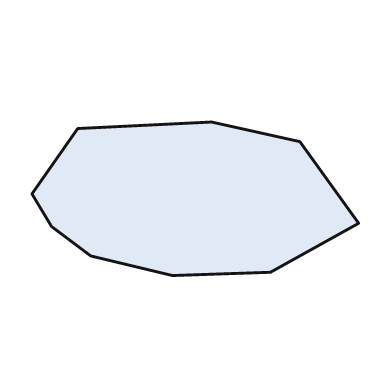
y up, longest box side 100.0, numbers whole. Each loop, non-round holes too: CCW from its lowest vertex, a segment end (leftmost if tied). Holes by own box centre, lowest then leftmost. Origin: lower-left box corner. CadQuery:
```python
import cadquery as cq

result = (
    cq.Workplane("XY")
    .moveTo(43.0, 0.0)
    .lineTo(73.0, 1.0)
    .lineTo(100.0, 16.0)
    .lineTo(82.0, 41.0)
    .lineTo(55.0, 47.0)
    .lineTo(14.0, 45.0)
    .lineTo(0.0, 25.0)
    .lineTo(6.0, 15.0)
    .lineTo(18.0, 6.0)
    .close()
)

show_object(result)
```